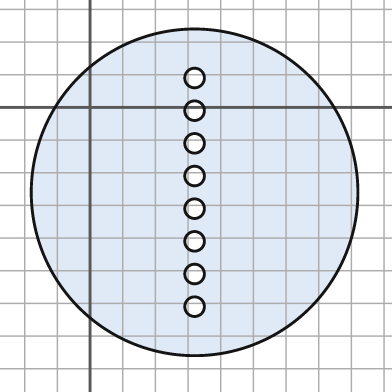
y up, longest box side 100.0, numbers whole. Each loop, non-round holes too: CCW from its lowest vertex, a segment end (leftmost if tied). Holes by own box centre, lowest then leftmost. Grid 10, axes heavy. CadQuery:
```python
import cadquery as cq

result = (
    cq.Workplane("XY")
    .moveTo(32.0, -26.0)
    .circle(50.0)
    .moveTo(32.0, -61.0)
    .circle(3.0)
    .moveTo(32.0, -51.0)
    .circle(3.0)
    .moveTo(32.0, -41.0)
    .circle(3.0)
    .moveTo(32.0, -31.0)
    .circle(3.0)
    .moveTo(32.0, -21.0)
    .circle(3.0)
    .moveTo(32.0, -11.0)
    .circle(3.0)
    .moveTo(32.0, -1.0)
    .circle(3.0)
    .moveTo(32.0, 9.0)
    .circle(3.0)
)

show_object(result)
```